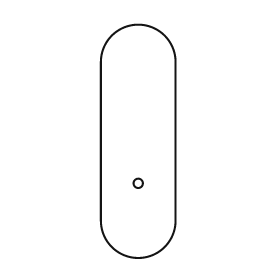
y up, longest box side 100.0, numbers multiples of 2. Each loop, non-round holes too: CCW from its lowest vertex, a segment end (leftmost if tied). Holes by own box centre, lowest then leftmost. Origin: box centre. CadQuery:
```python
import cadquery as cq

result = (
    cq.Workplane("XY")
    .moveTo(-16.0, -34.0)
    .threePointArc((0.0, -50.0), (16.0, -34.0))
    .lineTo(16.0, 34.0)
    .threePointArc((0.0, 50.0), (-16.0, 34.0))
    .close()
    .moveTo(0.0, -18.0)
    .circle(2.0)
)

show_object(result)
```